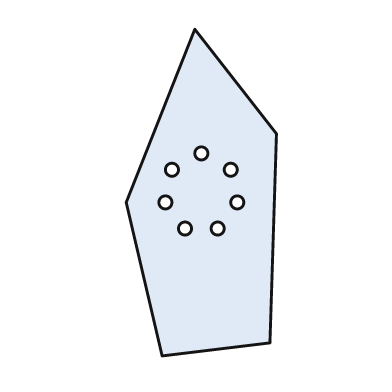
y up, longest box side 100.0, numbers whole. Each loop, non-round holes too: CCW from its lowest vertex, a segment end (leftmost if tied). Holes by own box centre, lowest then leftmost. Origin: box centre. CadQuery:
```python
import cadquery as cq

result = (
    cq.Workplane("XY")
    .moveTo(-12.0, -50.0)
    .lineTo(21.0, -46.0)
    .lineTo(23.0, 18.0)
    .lineTo(-2.0, 50.0)
    .lineTo(-23.0, -3.0)
    .close()
    .moveTo(-5.0, -11.0)
    .circle(2.0)
    .moveTo(5.0, -11.0)
    .circle(2.0)
    .moveTo(-11.0, -3.0)
    .circle(2.0)
    .moveTo(11.0, -3.0)
    .circle(2.0)
    .moveTo(-9.0, 7.0)
    .circle(2.0)
    .moveTo(9.0, 7.0)
    .circle(2.0)
    .moveTo(0.0, 12.0)
    .circle(2.0)
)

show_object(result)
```